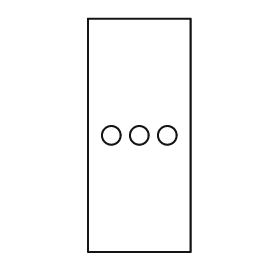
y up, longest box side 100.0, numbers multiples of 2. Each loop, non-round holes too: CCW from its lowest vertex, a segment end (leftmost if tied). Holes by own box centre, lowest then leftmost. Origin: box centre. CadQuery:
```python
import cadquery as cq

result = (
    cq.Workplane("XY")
    .moveTo(-22.0, -50.0)
    .lineTo(22.0, -50.0)
    .lineTo(22.0, 50.0)
    .lineTo(-22.0, 50.0)
    .close()
    .moveTo(-12.0, 0.0)
    .circle(4.0)
    .moveTo(0.0, 0.0)
    .circle(4.0)
    .moveTo(12.0, 0.0)
    .circle(4.0)
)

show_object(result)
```